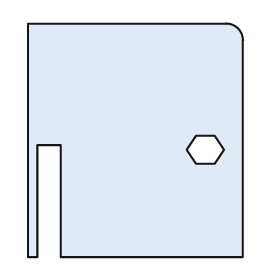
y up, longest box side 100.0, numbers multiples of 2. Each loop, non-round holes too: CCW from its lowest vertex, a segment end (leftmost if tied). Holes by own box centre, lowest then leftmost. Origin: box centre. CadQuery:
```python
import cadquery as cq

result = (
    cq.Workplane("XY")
    .moveTo(-46.0, -50.0)
    .lineTo(-42.0, -50.0)
    .lineTo(-42.0, -2.0)
    .lineTo(-32.0, -2.0)
    .lineTo(-32.0, -50.0)
    .lineTo(46.0, -50.0)
    .lineTo(46.0, 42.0)
    .threePointArc((44.0, 48.0), (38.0, 50.0))
    .lineTo(-46.0, 50.0)
    .close()
    .moveTo(26.0, -10.0)
    .lineTo(34.0, -10.0)
    .lineTo(38.0, -4.0)
    .lineTo(34.0, 2.0)
    .lineTo(26.0, 2.0)
    .lineTo(22.0, -4.0)
    .close()
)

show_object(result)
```